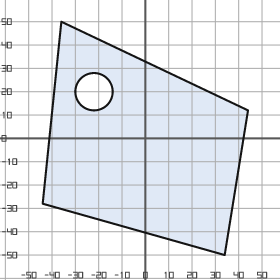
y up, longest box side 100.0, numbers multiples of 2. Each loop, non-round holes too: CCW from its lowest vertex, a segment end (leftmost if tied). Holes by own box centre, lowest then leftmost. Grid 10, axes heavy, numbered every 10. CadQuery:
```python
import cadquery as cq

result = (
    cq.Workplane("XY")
    .moveTo(34.0, -50.0)
    .lineTo(44.0, 12.0)
    .lineTo(-36.0, 50.0)
    .lineTo(-44.0, -28.0)
    .close()
    .moveTo(-22.0, 20.0)
    .circle(8.0)
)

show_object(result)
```